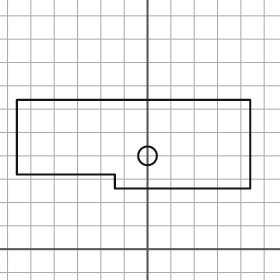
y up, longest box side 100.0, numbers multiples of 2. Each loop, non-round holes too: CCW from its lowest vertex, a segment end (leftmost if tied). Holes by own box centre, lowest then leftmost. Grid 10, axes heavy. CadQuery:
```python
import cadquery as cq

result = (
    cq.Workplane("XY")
    .moveTo(-14.0, 26.0)
    .lineTo(44.0, 26.0)
    .lineTo(44.0, 64.0)
    .lineTo(-56.0, 64.0)
    .lineTo(-56.0, 32.0)
    .lineTo(-14.0, 32.0)
    .close()
    .moveTo(0.0, 40.0)
    .circle(4.0)
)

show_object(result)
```